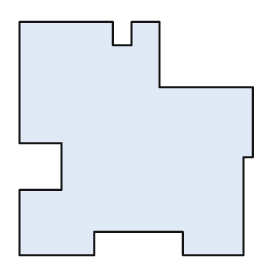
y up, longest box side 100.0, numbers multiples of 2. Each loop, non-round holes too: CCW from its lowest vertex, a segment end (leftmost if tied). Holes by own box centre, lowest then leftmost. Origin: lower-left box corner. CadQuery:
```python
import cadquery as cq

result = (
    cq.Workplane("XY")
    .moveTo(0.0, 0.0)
    .lineTo(32.0, 0.0)
    .lineTo(32.0, 10.0)
    .lineTo(70.0, 10.0)
    .lineTo(70.0, 0.0)
    .lineTo(96.0, 0.0)
    .lineTo(96.0, 42.0)
    .lineTo(100.0, 42.0)
    .lineTo(100.0, 72.0)
    .lineTo(60.0, 72.0)
    .lineTo(60.0, 100.0)
    .lineTo(48.0, 100.0)
    .lineTo(48.0, 90.0)
    .lineTo(40.0, 90.0)
    .lineTo(40.0, 100.0)
    .lineTo(0.0, 100.0)
    .lineTo(0.0, 48.0)
    .lineTo(18.0, 48.0)
    .lineTo(18.0, 28.0)
    .lineTo(0.0, 28.0)
    .close()
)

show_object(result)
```